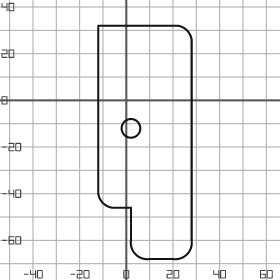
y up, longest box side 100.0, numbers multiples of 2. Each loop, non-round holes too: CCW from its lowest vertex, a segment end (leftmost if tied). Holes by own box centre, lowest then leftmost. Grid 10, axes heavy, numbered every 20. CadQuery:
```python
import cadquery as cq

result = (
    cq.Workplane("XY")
    .moveTo(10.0, -68.0)
    .lineTo(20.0, -68.0)
    .threePointArc((26.0, -66.0), (28.0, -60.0))
    .lineTo(28.0, 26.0)
    .threePointArc((26.0, 30.0), (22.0, 32.0))
    .lineTo(-12.0, 32.0)
    .lineTo(-12.0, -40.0)
    .threePointArc((-10.0, -44.0), (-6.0, -46.0))
    .lineTo(2.0, -46.0)
    .lineTo(2.0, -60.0)
    .threePointArc((4.0, -66.0), (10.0, -68.0))
    .close()
    .moveTo(2.0, -12.0)
    .circle(4.0)
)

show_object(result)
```